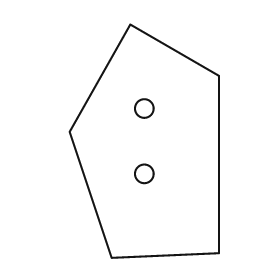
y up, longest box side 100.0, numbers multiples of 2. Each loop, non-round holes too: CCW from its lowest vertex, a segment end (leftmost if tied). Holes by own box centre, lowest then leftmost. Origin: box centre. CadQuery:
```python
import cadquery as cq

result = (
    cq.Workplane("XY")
    .moveTo(-14.0, -50.0)
    .lineTo(32.0, -48.0)
    .lineTo(32.0, 28.0)
    .lineTo(-6.0, 50.0)
    .lineTo(-32.0, 4.0)
    .close()
    .moveTo(0.0, -14.0)
    .circle(4.0)
    .moveTo(0.0, 14.0)
    .circle(4.0)
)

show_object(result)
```